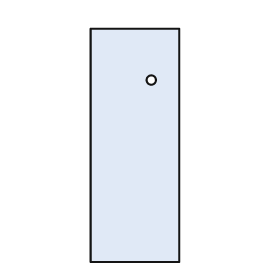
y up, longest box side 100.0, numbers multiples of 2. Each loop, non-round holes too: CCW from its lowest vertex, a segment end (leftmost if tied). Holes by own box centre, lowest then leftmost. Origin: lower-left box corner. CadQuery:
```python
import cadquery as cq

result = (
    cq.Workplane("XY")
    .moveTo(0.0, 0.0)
    .lineTo(38.0, 0.0)
    .lineTo(38.0, 100.0)
    .lineTo(0.0, 100.0)
    .close()
    .moveTo(26.0, 78.0)
    .circle(2.0)
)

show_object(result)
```